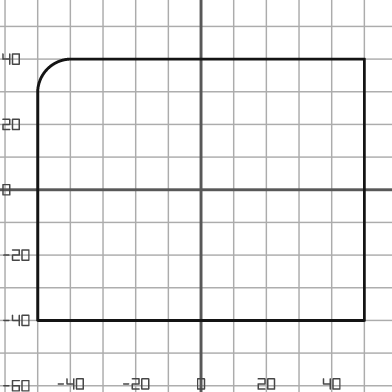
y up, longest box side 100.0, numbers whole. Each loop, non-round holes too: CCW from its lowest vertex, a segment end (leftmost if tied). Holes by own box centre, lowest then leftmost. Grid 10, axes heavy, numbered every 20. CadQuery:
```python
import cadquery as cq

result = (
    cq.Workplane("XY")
    .moveTo(-50.0, -40.0)
    .lineTo(50.0, -40.0)
    .lineTo(50.0, 40.0)
    .lineTo(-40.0, 40.0)
    .threePointArc((-47.0, 37.0), (-50.0, 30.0))
    .close()
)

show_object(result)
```